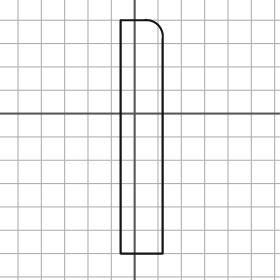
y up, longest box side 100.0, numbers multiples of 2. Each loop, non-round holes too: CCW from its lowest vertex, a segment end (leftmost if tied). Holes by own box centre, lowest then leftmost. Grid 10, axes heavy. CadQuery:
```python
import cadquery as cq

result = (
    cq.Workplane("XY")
    .moveTo(-6.0, -60.0)
    .lineTo(12.0, -60.0)
    .lineTo(12.0, 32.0)
    .threePointArc((10.0, 38.0), (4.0, 40.0))
    .lineTo(-6.0, 40.0)
    .close()
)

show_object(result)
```